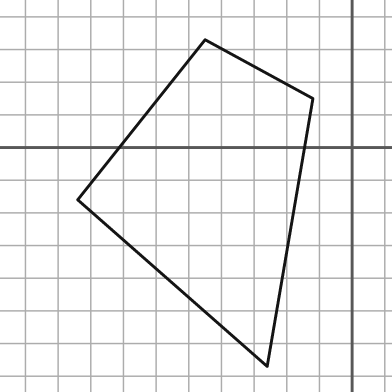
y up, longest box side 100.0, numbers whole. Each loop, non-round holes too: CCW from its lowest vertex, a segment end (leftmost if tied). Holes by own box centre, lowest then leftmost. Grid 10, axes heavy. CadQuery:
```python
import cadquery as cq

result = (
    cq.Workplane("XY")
    .moveTo(-26.0, -67.0)
    .lineTo(-12.0, 15.0)
    .lineTo(-45.0, 33.0)
    .lineTo(-84.0, -16.0)
    .close()
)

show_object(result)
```